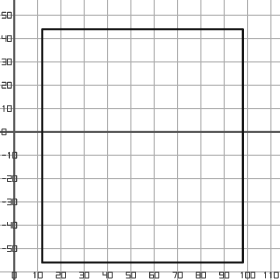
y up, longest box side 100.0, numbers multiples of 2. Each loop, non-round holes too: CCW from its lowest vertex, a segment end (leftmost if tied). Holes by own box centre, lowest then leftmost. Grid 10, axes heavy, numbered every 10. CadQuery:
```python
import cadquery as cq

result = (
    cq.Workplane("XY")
    .moveTo(12.0, -56.0)
    .lineTo(98.0, -56.0)
    .lineTo(98.0, 44.0)
    .lineTo(12.0, 44.0)
    .close()
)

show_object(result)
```